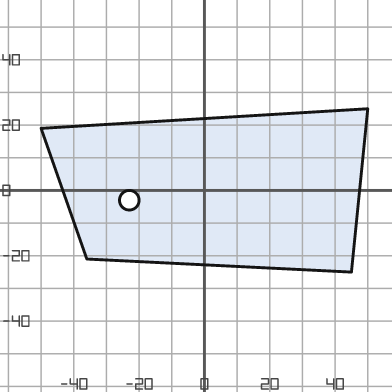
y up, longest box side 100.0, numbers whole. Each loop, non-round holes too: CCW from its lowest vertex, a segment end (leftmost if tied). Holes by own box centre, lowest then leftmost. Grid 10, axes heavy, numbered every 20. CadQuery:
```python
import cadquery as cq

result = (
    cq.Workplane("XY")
    .moveTo(45.0, -25.0)
    .lineTo(50.0, 25.0)
    .lineTo(-50.0, 19.0)
    .lineTo(-36.0, -21.0)
    .close()
    .moveTo(-23.0, -3.0)
    .circle(3.0)
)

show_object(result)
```